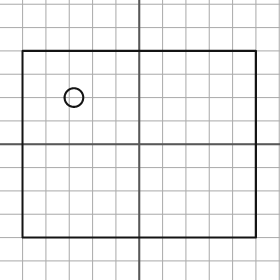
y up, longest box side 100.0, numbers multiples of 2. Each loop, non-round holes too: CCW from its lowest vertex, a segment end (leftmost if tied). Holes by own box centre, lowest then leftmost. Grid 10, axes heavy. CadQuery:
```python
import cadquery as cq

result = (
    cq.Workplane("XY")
    .moveTo(-50.0, -40.0)
    .lineTo(50.0, -40.0)
    .lineTo(50.0, 40.0)
    .lineTo(-50.0, 40.0)
    .close()
    .moveTo(-28.0, 20.0)
    .circle(4.0)
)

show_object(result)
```